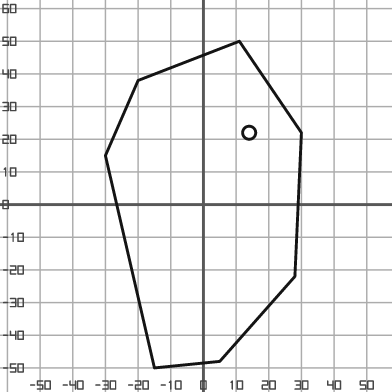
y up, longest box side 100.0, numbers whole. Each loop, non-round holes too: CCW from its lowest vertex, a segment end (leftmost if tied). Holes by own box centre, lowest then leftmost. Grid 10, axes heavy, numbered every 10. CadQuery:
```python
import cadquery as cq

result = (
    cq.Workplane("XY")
    .moveTo(-15.0, -50.0)
    .lineTo(5.0, -48.0)
    .lineTo(28.0, -22.0)
    .lineTo(30.0, 22.0)
    .lineTo(11.0, 50.0)
    .lineTo(-20.0, 38.0)
    .lineTo(-30.0, 15.0)
    .close()
    .moveTo(14.0, 22.0)
    .circle(2.0)
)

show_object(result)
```